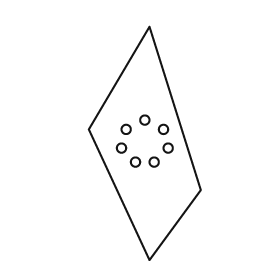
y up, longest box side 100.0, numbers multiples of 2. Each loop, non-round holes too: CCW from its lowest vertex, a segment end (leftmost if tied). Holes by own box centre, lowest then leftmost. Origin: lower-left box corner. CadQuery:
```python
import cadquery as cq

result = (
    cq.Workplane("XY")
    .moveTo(26.0, 0.0)
    .lineTo(48.0, 30.0)
    .lineTo(26.0, 100.0)
    .lineTo(0.0, 56.0)
    .close()
    .moveTo(20.0, 42.0)
    .circle(2.0)
    .moveTo(28.0, 42.0)
    .circle(2.0)
    .moveTo(14.0, 48.0)
    .circle(2.0)
    .moveTo(34.0, 48.0)
    .circle(2.0)
    .moveTo(16.0, 56.0)
    .circle(2.0)
    .moveTo(32.0, 56.0)
    .circle(2.0)
    .moveTo(24.0, 60.0)
    .circle(2.0)
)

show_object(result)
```